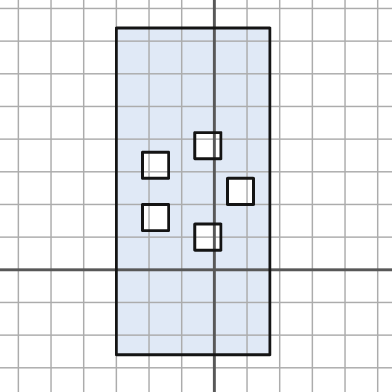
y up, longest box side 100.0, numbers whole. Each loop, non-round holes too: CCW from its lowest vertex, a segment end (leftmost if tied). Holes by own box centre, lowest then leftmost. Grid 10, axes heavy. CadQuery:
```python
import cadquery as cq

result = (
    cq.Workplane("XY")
    .moveTo(-30.0, -26.0)
    .lineTo(17.0, -26.0)
    .lineTo(17.0, 74.0)
    .lineTo(-30.0, 74.0)
    .close()
    .moveTo(-6.0, 6.0)
    .lineTo(2.0, 6.0)
    .lineTo(2.0, 14.0)
    .lineTo(-6.0, 14.0)
    .close()
    .moveTo(-22.0, 12.0)
    .lineTo(-14.0, 12.0)
    .lineTo(-14.0, 20.0)
    .lineTo(-22.0, 20.0)
    .close()
    .moveTo(4.0, 20.0)
    .lineTo(12.0, 20.0)
    .lineTo(12.0, 28.0)
    .lineTo(4.0, 28.0)
    .close()
    .moveTo(-22.0, 28.0)
    .lineTo(-14.0, 28.0)
    .lineTo(-14.0, 36.0)
    .lineTo(-22.0, 36.0)
    .close()
    .moveTo(-6.0, 34.0)
    .lineTo(2.0, 34.0)
    .lineTo(2.0, 42.0)
    .lineTo(-6.0, 42.0)
    .close()
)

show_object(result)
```